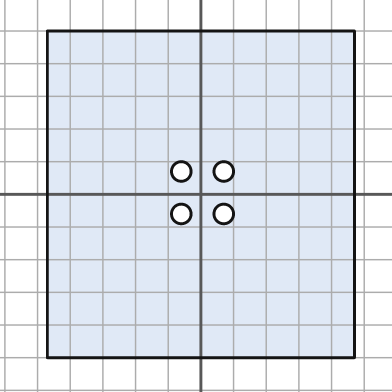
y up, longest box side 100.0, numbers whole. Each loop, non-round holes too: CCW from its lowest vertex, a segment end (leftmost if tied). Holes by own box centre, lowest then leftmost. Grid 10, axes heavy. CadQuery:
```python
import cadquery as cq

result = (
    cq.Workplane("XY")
    .moveTo(-47.0, -50.0)
    .lineTo(47.0, -50.0)
    .lineTo(47.0, 50.0)
    .lineTo(-47.0, 50.0)
    .close()
    .moveTo(-6.0, -6.0)
    .circle(3.0)
    .moveTo(7.0, -6.0)
    .circle(3.0)
    .moveTo(-6.0, 7.0)
    .circle(3.0)
    .moveTo(7.0, 7.0)
    .circle(3.0)
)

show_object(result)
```